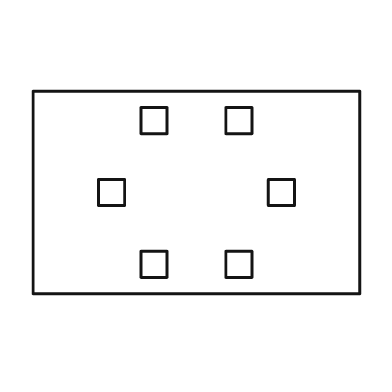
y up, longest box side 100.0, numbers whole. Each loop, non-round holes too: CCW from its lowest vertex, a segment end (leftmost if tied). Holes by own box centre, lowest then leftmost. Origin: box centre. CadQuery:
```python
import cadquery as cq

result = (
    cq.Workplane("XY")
    .moveTo(-50.0, -31.0)
    .lineTo(50.0, -31.0)
    .lineTo(50.0, 31.0)
    .lineTo(-50.0, 31.0)
    .close()
    .moveTo(-17.0, -26.0)
    .lineTo(-9.0, -26.0)
    .lineTo(-9.0, -18.0)
    .lineTo(-17.0, -18.0)
    .close()
    .moveTo(9.0, -26.0)
    .lineTo(17.0, -26.0)
    .lineTo(17.0, -18.0)
    .lineTo(9.0, -18.0)
    .close()
    .moveTo(-30.0, -4.0)
    .lineTo(-22.0, -4.0)
    .lineTo(-22.0, 4.0)
    .lineTo(-30.0, 4.0)
    .close()
    .moveTo(22.0, -4.0)
    .lineTo(30.0, -4.0)
    .lineTo(30.0, 4.0)
    .lineTo(22.0, 4.0)
    .close()
    .moveTo(-17.0, 18.0)
    .lineTo(-9.0, 18.0)
    .lineTo(-9.0, 26.0)
    .lineTo(-17.0, 26.0)
    .close()
    .moveTo(9.0, 18.0)
    .lineTo(17.0, 18.0)
    .lineTo(17.0, 26.0)
    .lineTo(9.0, 26.0)
    .close()
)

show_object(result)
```